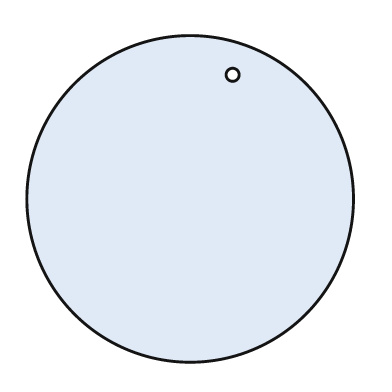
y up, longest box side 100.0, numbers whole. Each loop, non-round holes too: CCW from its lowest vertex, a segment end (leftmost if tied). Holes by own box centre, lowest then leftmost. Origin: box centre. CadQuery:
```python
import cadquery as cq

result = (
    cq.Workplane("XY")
    .moveTo(0.0, 0.0)
    .circle(50.0)
    .moveTo(13.0, 38.0)
    .circle(2.0)
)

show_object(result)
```